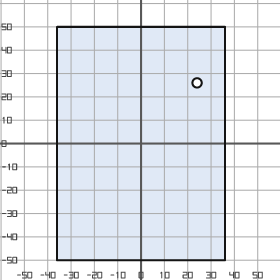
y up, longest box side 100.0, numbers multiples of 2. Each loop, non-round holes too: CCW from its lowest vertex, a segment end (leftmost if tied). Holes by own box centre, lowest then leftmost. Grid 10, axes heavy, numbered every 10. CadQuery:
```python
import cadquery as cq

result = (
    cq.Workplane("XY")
    .moveTo(-36.0, -50.0)
    .lineTo(36.0, -50.0)
    .lineTo(36.0, 50.0)
    .lineTo(-36.0, 50.0)
    .close()
    .moveTo(24.0, 26.0)
    .circle(2.0)
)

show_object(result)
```